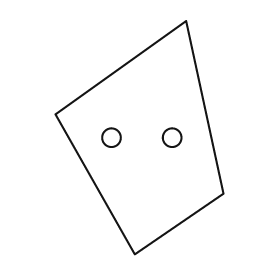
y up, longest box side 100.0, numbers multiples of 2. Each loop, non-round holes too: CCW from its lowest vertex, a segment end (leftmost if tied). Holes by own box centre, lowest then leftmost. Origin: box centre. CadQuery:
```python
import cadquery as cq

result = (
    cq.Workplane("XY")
    .moveTo(-2.0, -50.0)
    .lineTo(36.0, -24.0)
    .lineTo(20.0, 50.0)
    .lineTo(-36.0, 10.0)
    .close()
    .moveTo(-12.0, 0.0)
    .circle(4.0)
    .moveTo(14.0, 0.0)
    .circle(4.0)
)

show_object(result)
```